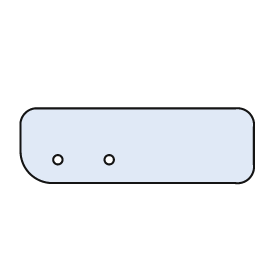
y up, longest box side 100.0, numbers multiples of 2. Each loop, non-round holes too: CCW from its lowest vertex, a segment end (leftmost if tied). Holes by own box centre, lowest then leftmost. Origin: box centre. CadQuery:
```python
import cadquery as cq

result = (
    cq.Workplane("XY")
    .moveTo(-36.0, -16.0)
    .lineTo(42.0, -16.0)
    .threePointArc((48.0, -14.0), (50.0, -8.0))
    .lineTo(50.0, 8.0)
    .threePointArc((48.0, 14.0), (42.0, 16.0))
    .lineTo(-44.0, 16.0)
    .threePointArc((-48.0, 14.0), (-50.0, 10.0))
    .lineTo(-50.0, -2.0)
    .threePointArc((-46.0, -12.0), (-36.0, -16.0))
    .close()
    .moveTo(-34.0, -6.0)
    .circle(2.0)
    .moveTo(-12.0, -6.0)
    .circle(2.0)
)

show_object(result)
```